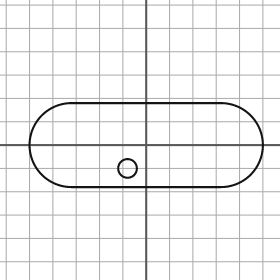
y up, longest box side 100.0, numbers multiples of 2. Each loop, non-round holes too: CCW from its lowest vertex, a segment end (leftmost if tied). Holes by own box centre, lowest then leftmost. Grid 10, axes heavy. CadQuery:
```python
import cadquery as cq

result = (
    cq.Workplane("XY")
    .moveTo(-32.0, -18.0)
    .lineTo(32.0, -18.0)
    .threePointArc((50.0, 0.0), (32.0, 18.0))
    .lineTo(-32.0, 18.0)
    .threePointArc((-50.0, 0.0), (-32.0, -18.0))
    .close()
    .moveTo(-8.0, -10.0)
    .circle(4.0)
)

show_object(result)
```